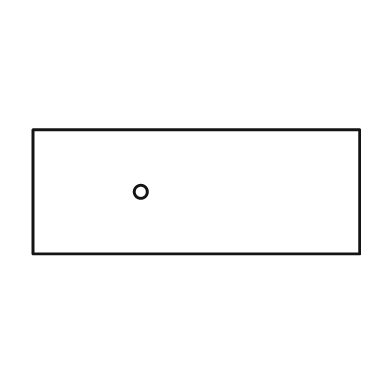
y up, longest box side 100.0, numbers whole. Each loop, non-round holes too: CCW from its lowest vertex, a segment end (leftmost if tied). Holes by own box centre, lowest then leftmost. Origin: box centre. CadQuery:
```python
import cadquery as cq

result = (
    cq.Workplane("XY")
    .moveTo(-50.0, -19.0)
    .lineTo(50.0, -19.0)
    .lineTo(50.0, 19.0)
    .lineTo(-50.0, 19.0)
    .close()
    .moveTo(-17.0, 0.0)
    .circle(2.0)
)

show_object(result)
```